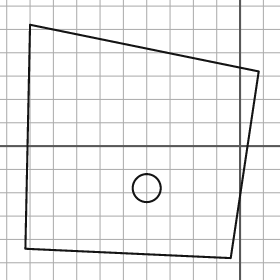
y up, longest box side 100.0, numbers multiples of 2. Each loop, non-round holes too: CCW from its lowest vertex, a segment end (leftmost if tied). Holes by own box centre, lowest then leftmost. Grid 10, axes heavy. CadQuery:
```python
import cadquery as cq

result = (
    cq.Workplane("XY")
    .moveTo(-4.0, -48.0)
    .lineTo(8.0, 32.0)
    .lineTo(-90.0, 52.0)
    .lineTo(-92.0, -44.0)
    .close()
    .moveTo(-40.0, -18.0)
    .circle(6.0)
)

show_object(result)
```